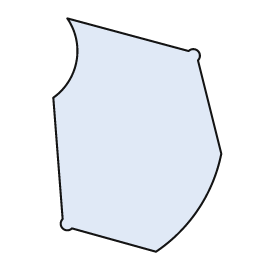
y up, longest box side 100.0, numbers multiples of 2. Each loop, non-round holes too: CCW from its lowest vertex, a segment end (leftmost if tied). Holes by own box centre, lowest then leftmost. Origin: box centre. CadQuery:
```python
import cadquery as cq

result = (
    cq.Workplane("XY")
    .moveTo(8.0, -50.0)
    .threePointArc((26.0, -32.0), (36.0, -8.0))
    .lineTo(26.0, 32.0)
    .threePointArc((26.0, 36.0), (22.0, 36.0))
    .lineTo(-30.0, 50.0)
    .threePointArc((-26.0, 32.0), (-36.0, 16.0))
    .lineTo(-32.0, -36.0)
    .threePointArc((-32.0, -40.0), (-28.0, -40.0))
    .close()
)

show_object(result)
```